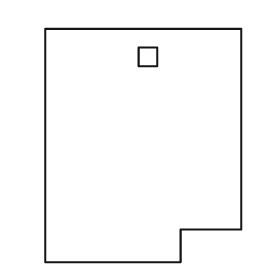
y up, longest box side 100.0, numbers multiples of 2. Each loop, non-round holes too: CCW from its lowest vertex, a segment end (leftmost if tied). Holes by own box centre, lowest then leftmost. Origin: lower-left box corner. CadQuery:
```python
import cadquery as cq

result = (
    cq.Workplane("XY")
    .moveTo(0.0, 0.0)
    .lineTo(58.0, 0.0)
    .lineTo(58.0, 14.0)
    .lineTo(84.0, 14.0)
    .lineTo(84.0, 100.0)
    .lineTo(0.0, 100.0)
    .close()
    .moveTo(40.0, 84.0)
    .lineTo(48.0, 84.0)
    .lineTo(48.0, 92.0)
    .lineTo(40.0, 92.0)
    .close()
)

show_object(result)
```